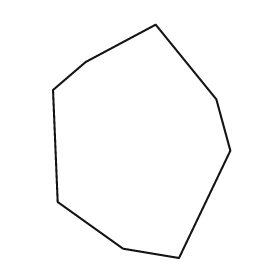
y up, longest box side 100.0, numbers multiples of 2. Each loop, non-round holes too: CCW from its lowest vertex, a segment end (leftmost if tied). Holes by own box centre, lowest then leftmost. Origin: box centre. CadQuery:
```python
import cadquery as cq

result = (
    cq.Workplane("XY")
    .moveTo(16.0, -50.0)
    .lineTo(38.0, -4.0)
    .lineTo(32.0, 18.0)
    .lineTo(6.0, 50.0)
    .lineTo(-24.0, 34.0)
    .lineTo(-38.0, 22.0)
    .lineTo(-36.0, -26.0)
    .lineTo(-8.0, -46.0)
    .close()
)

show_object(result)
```